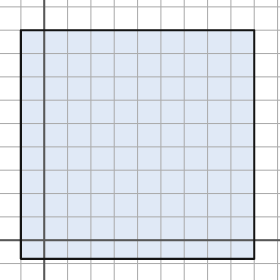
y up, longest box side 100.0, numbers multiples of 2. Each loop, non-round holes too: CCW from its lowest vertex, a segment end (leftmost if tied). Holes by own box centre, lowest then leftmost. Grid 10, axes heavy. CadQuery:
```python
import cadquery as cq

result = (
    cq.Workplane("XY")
    .moveTo(-10.0, -8.0)
    .lineTo(90.0, -8.0)
    .lineTo(90.0, 90.0)
    .lineTo(-10.0, 90.0)
    .close()
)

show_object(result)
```